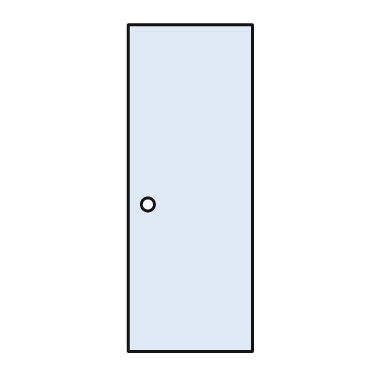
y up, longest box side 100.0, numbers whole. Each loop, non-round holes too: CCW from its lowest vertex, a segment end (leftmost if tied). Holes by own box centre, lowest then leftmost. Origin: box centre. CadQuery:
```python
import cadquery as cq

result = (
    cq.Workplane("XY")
    .moveTo(-19.0, -50.0)
    .lineTo(19.0, -50.0)
    .lineTo(19.0, 50.0)
    .lineTo(-19.0, 50.0)
    .close()
    .moveTo(-13.0, -5.0)
    .circle(2.0)
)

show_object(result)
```